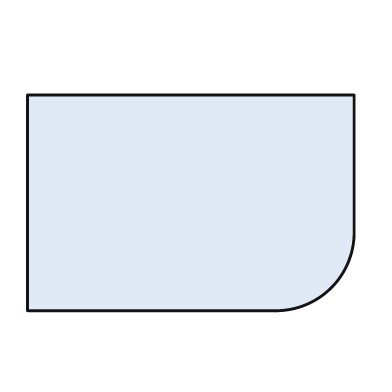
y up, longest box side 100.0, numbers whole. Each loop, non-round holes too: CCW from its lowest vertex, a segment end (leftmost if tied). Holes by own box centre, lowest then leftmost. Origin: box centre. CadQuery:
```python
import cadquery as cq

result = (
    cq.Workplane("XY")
    .moveTo(-50.0, -33.0)
    .lineTo(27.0, -33.0)
    .threePointArc((43.0, -26.0), (50.0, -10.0))
    .lineTo(50.0, 33.0)
    .lineTo(-50.0, 33.0)
    .close()
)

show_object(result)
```